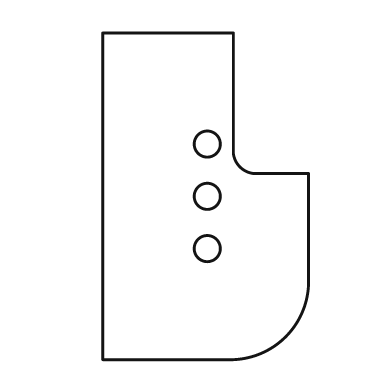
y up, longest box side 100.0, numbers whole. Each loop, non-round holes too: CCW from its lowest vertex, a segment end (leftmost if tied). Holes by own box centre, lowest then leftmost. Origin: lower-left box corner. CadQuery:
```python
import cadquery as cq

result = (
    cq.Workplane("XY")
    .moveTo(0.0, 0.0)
    .lineTo(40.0, 0.0)
    .threePointArc((56.0, 7.0), (63.0, 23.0))
    .lineTo(63.0, 57.0)
    .lineTo(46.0, 57.0)
    .threePointArc((42.0, 59.0), (40.0, 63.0))
    .lineTo(40.0, 100.0)
    .lineTo(0.0, 100.0)
    .close()
    .moveTo(32.0, 34.0)
    .circle(4.0)
    .moveTo(32.0, 50.0)
    .circle(4.0)
    .moveTo(32.0, 66.0)
    .circle(4.0)
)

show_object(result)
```